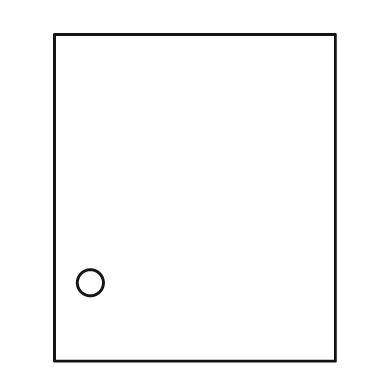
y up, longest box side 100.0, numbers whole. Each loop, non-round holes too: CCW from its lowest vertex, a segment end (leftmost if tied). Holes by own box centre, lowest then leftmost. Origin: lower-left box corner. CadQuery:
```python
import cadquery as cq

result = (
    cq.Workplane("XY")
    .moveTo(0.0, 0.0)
    .lineTo(86.0, 0.0)
    .lineTo(86.0, 100.0)
    .lineTo(0.0, 100.0)
    .close()
    .moveTo(11.0, 24.0)
    .circle(4.0)
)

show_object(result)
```